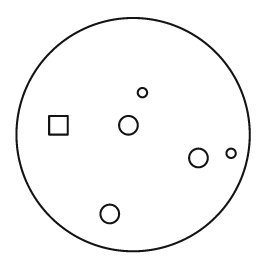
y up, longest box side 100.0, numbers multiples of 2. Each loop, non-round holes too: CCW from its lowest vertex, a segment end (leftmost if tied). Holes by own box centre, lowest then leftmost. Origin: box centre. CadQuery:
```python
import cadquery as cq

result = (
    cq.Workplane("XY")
    .moveTo(0.0, 0.0)
    .circle(50.0)
    .moveTo(-10.0, -34.0)
    .circle(4.0)
    .moveTo(28.0, -10.0)
    .circle(4.0)
    .moveTo(42.0, -8.0)
    .circle(2.0)
    .moveTo(-36.0, 0.0)
    .lineTo(-28.0, 0.0)
    .lineTo(-28.0, 8.0)
    .lineTo(-36.0, 8.0)
    .close()
    .moveTo(-2.0, 4.0)
    .circle(4.0)
    .moveTo(4.0, 18.0)
    .circle(2.0)
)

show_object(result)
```